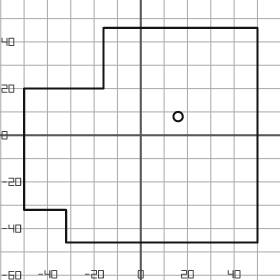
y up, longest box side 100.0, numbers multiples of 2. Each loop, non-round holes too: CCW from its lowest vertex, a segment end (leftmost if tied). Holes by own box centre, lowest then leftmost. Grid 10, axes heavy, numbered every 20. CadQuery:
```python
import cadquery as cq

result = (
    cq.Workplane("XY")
    .moveTo(-32.0, -46.0)
    .lineTo(50.0, -46.0)
    .lineTo(50.0, 46.0)
    .lineTo(-16.0, 46.0)
    .lineTo(-16.0, 20.0)
    .lineTo(-50.0, 20.0)
    .lineTo(-50.0, -32.0)
    .lineTo(-32.0, -32.0)
    .close()
    .moveTo(16.0, 8.0)
    .circle(2.0)
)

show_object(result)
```